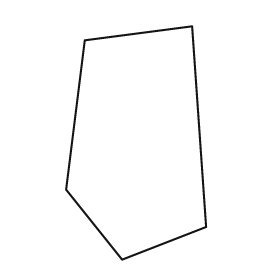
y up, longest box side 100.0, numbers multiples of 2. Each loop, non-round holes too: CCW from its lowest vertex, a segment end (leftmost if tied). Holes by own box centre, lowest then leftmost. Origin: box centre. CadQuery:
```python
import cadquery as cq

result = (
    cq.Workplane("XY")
    .moveTo(-6.0, -50.0)
    .lineTo(30.0, -36.0)
    .lineTo(24.0, 50.0)
    .lineTo(-22.0, 44.0)
    .lineTo(-30.0, -20.0)
    .close()
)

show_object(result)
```